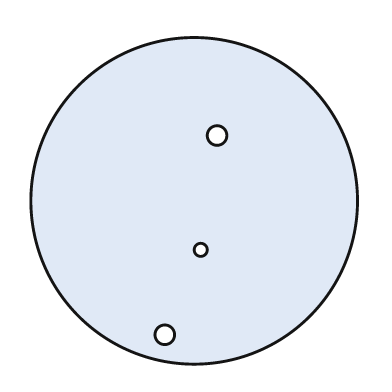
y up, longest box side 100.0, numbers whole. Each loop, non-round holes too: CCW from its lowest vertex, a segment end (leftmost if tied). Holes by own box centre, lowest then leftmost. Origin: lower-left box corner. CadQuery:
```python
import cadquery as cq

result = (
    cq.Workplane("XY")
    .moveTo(50.0, 50.0)
    .circle(50.0)
    .moveTo(41.0, 9.0)
    .circle(3.0)
    .moveTo(52.0, 35.0)
    .circle(2.0)
    .moveTo(57.0, 70.0)
    .circle(3.0)
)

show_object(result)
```